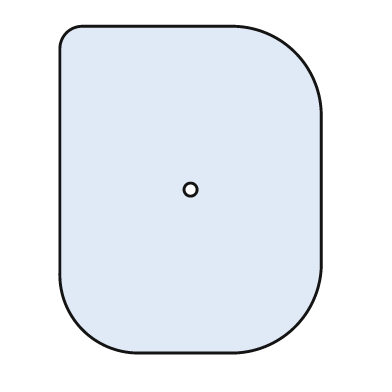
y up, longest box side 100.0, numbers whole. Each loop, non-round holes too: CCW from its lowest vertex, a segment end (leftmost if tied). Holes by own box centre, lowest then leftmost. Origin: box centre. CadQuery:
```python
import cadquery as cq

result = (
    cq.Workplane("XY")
    .moveTo(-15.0, -50.0)
    .lineTo(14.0, -50.0)
    .threePointArc((32.0, -42.0), (40.0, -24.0))
    .lineTo(40.0, 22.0)
    .threePointArc((32.0, 42.0), (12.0, 50.0))
    .lineTo(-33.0, 50.0)
    .threePointArc((-38.0, 48.0), (-40.0, 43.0))
    .lineTo(-40.0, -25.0)
    .threePointArc((-33.0, -43.0), (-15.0, -50.0))
    .close()
    .moveTo(0.0, 0.0)
    .circle(2.0)
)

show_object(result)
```